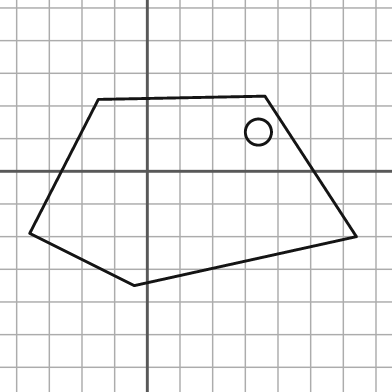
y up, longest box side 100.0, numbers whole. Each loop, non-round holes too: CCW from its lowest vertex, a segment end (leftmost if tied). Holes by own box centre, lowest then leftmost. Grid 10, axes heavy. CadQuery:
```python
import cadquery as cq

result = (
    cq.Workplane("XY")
    .moveTo(-4.0, -35.0)
    .lineTo(64.0, -20.0)
    .lineTo(36.0, 23.0)
    .lineTo(-15.0, 22.0)
    .lineTo(-36.0, -19.0)
    .close()
    .moveTo(34.0, 12.0)
    .circle(4.0)
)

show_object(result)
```